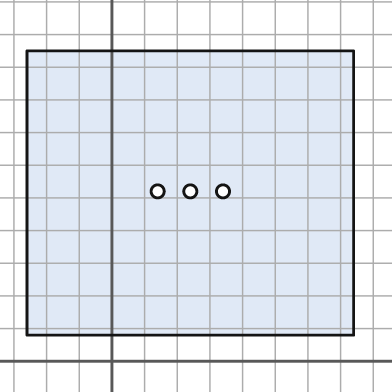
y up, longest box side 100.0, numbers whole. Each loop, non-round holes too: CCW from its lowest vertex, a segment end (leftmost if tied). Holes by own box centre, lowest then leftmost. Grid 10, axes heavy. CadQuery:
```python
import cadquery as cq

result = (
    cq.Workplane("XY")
    .moveTo(-26.0, 8.0)
    .lineTo(74.0, 8.0)
    .lineTo(74.0, 95.0)
    .lineTo(-26.0, 95.0)
    .close()
    .moveTo(14.0, 52.0)
    .circle(2.0)
    .moveTo(24.0, 52.0)
    .circle(2.0)
    .moveTo(34.0, 52.0)
    .circle(2.0)
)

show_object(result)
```